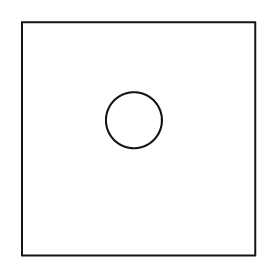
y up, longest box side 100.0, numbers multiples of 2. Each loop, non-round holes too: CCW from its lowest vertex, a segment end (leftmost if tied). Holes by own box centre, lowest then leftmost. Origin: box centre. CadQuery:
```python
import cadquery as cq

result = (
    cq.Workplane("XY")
    .moveTo(-50.0, -50.0)
    .lineTo(50.0, -50.0)
    .lineTo(50.0, 50.0)
    .lineTo(-50.0, 50.0)
    .close()
    .moveTo(-2.0, 8.0)
    .circle(12.0)
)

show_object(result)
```